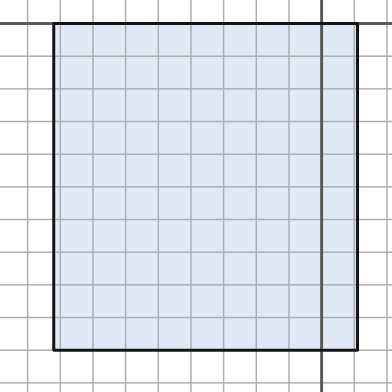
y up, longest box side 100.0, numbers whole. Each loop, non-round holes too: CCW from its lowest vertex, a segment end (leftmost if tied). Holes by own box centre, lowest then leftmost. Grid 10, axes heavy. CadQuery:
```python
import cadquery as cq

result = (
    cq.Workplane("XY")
    .moveTo(-82.0, -100.0)
    .lineTo(11.0, -100.0)
    .lineTo(11.0, 0.0)
    .lineTo(-82.0, 0.0)
    .close()
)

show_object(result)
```